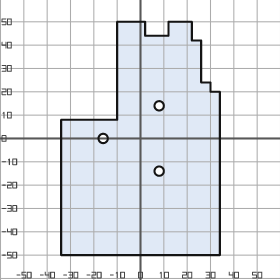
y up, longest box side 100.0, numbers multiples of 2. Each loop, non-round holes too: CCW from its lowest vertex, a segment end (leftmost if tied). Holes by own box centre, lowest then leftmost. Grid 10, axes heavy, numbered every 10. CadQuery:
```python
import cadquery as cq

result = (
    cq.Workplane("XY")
    .moveTo(-34.0, -50.0)
    .lineTo(34.0, -50.0)
    .lineTo(34.0, 20.0)
    .lineTo(30.0, 20.0)
    .lineTo(30.0, 24.0)
    .lineTo(26.0, 24.0)
    .lineTo(26.0, 42.0)
    .lineTo(22.0, 42.0)
    .lineTo(22.0, 50.0)
    .lineTo(12.0, 50.0)
    .lineTo(12.0, 44.0)
    .lineTo(2.0, 44.0)
    .lineTo(2.0, 50.0)
    .lineTo(-10.0, 50.0)
    .lineTo(-10.0, 8.0)
    .lineTo(-34.0, 8.0)
    .close()
    .moveTo(8.0, -14.0)
    .circle(2.0)
    .moveTo(-16.0, 0.0)
    .circle(2.0)
    .moveTo(8.0, 14.0)
    .circle(2.0)
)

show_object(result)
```